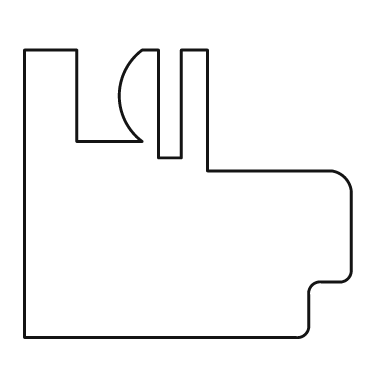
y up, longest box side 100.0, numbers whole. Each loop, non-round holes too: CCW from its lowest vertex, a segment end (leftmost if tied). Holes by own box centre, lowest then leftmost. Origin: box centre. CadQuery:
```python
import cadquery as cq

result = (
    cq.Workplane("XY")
    .moveTo(-50.0, -44.0)
    .lineTo(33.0, -44.0)
    .threePointArc((36.0, -43.0), (37.0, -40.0))
    .lineTo(37.0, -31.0)
    .threePointArc((38.0, -28.0), (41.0, -27.0))
    .lineTo(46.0, -27.0)
    .threePointArc((49.0, -26.0), (50.0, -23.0))
    .lineTo(50.0, 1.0)
    .threePointArc((48.0, 5.0), (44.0, 7.0))
    .lineTo(6.0, 7.0)
    .lineTo(6.0, 44.0)
    .lineTo(-2.0, 44.0)
    .lineTo(-2.0, 11.0)
    .lineTo(-9.0, 11.0)
    .lineTo(-9.0, 44.0)
    .lineTo(-14.0, 44.0)
    .threePointArc((-21.0, 30.0), (-14.0, 16.0))
    .lineTo(-34.0, 16.0)
    .lineTo(-34.0, 44.0)
    .lineTo(-50.0, 44.0)
    .close()
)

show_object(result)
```